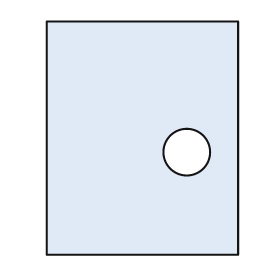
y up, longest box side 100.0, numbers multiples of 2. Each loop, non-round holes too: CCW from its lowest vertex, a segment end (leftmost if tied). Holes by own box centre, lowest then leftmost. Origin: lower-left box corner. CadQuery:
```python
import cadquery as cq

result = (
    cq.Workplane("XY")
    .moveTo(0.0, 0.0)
    .lineTo(82.0, 0.0)
    .lineTo(82.0, 100.0)
    .lineTo(0.0, 100.0)
    .close()
    .moveTo(60.0, 44.0)
    .circle(10.0)
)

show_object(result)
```